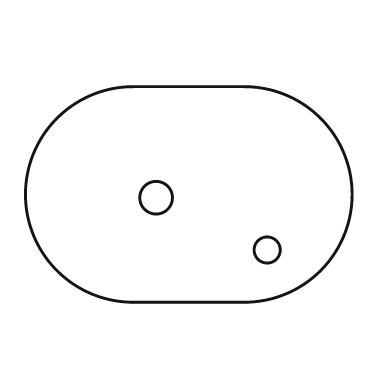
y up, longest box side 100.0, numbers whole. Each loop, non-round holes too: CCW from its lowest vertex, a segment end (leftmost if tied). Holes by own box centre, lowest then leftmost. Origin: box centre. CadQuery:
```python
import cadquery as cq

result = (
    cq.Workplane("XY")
    .moveTo(-17.0, -33.0)
    .lineTo(17.0, -33.0)
    .threePointArc((50.0, 0.0), (17.0, 33.0))
    .lineTo(-17.0, 33.0)
    .threePointArc((-50.0, 0.0), (-17.0, -33.0))
    .close()
    .moveTo(24.0, -17.0)
    .circle(4.0)
    .moveTo(-10.0, -1.0)
    .circle(5.0)
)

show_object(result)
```